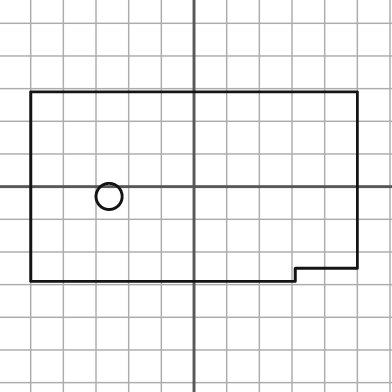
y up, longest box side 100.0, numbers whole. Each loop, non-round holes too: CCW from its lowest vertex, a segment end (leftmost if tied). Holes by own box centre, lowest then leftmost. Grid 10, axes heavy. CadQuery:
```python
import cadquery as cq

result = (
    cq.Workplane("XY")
    .moveTo(-50.0, -29.0)
    .lineTo(31.0, -29.0)
    .lineTo(31.0, -25.0)
    .lineTo(50.0, -25.0)
    .lineTo(50.0, 29.0)
    .lineTo(-50.0, 29.0)
    .close()
    .moveTo(-26.0, -3.0)
    .circle(4.0)
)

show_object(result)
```